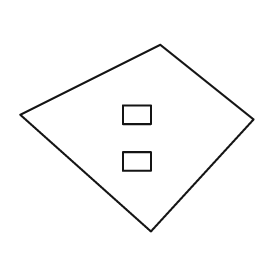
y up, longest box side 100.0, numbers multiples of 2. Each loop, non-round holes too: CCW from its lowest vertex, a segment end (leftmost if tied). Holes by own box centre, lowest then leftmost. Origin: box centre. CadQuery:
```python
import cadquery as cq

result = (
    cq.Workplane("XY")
    .moveTo(6.0, -40.0)
    .lineTo(50.0, 8.0)
    .lineTo(10.0, 40.0)
    .lineTo(-50.0, 10.0)
    .close()
    .moveTo(-6.0, -14.0)
    .lineTo(6.0, -14.0)
    .lineTo(6.0, -6.0)
    .lineTo(-6.0, -6.0)
    .close()
    .moveTo(-6.0, 6.0)
    .lineTo(6.0, 6.0)
    .lineTo(6.0, 14.0)
    .lineTo(-6.0, 14.0)
    .close()
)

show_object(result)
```